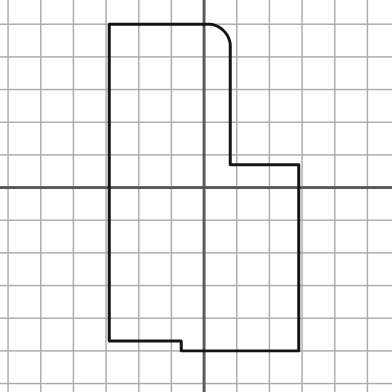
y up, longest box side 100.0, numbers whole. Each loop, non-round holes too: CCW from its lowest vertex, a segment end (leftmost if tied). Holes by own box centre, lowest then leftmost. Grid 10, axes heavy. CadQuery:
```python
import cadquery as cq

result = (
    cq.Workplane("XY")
    .moveTo(-7.0, -50.0)
    .lineTo(29.0, -50.0)
    .lineTo(29.0, 7.0)
    .lineTo(8.0, 7.0)
    .lineTo(8.0, 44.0)
    .threePointArc((6.0, 48.0), (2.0, 50.0))
    .lineTo(-29.0, 50.0)
    .lineTo(-29.0, -47.0)
    .lineTo(-7.0, -47.0)
    .close()
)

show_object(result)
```